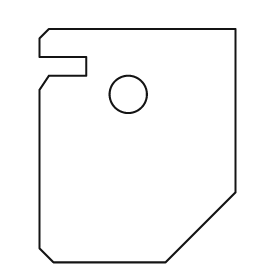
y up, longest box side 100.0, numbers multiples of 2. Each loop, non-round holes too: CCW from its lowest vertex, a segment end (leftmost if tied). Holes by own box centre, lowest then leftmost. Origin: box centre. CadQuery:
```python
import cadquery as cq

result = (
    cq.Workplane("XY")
    .moveTo(-36.0, -50.0)
    .lineTo(12.0, -50.0)
    .lineTo(42.0, -20.0)
    .lineTo(42.0, 50.0)
    .lineTo(-38.0, 50.0)
    .lineTo(-42.0, 46.0)
    .lineTo(-42.0, 38.0)
    .lineTo(-22.0, 38.0)
    .lineTo(-22.0, 30.0)
    .lineTo(-38.0, 30.0)
    .lineTo(-42.0, 24.0)
    .lineTo(-42.0, -44.0)
    .close()
    .moveTo(-4.0, 22.0)
    .circle(8.0)
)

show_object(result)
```